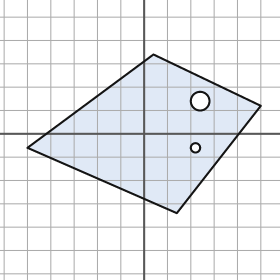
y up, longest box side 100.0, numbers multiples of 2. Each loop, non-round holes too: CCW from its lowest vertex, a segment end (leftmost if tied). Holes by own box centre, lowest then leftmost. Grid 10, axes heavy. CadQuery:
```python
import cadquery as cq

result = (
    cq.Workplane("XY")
    .moveTo(14.0, -34.0)
    .lineTo(50.0, 12.0)
    .lineTo(4.0, 34.0)
    .lineTo(-50.0, -6.0)
    .close()
    .moveTo(22.0, -6.0)
    .circle(2.0)
    .moveTo(24.0, 14.0)
    .circle(4.0)
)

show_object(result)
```